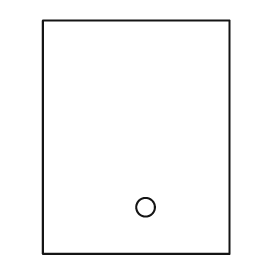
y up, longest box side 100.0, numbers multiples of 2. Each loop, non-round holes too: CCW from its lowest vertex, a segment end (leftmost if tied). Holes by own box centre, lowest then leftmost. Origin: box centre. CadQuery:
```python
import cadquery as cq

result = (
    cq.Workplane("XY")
    .moveTo(-40.0, -50.0)
    .lineTo(40.0, -50.0)
    .lineTo(40.0, 50.0)
    .lineTo(-40.0, 50.0)
    .close()
    .moveTo(4.0, -30.0)
    .circle(4.0)
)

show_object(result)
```